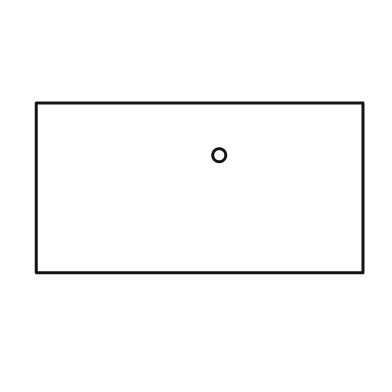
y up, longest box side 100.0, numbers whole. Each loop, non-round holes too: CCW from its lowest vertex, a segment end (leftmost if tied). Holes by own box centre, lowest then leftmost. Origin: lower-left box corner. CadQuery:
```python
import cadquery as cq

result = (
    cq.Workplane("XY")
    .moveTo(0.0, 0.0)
    .lineTo(100.0, 0.0)
    .lineTo(100.0, 52.0)
    .lineTo(0.0, 52.0)
    .close()
    .moveTo(56.0, 36.0)
    .circle(2.0)
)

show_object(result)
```